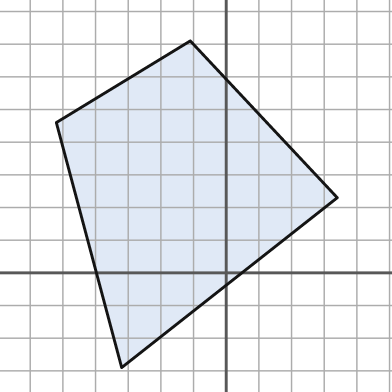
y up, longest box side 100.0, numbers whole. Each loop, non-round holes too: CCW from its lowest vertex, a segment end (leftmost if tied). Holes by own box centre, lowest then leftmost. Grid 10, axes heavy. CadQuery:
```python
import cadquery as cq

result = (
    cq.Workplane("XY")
    .moveTo(-32.0, -29.0)
    .lineTo(34.0, 23.0)
    .lineTo(-11.0, 71.0)
    .lineTo(-52.0, 46.0)
    .close()
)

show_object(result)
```